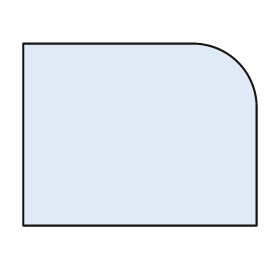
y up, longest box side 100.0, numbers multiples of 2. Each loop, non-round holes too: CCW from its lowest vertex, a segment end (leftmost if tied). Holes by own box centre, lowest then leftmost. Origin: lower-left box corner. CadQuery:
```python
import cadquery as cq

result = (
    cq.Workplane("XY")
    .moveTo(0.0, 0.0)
    .lineTo(100.0, 0.0)
    .lineTo(100.0, 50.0)
    .threePointArc((92.0, 70.0), (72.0, 78.0))
    .lineTo(0.0, 78.0)
    .close()
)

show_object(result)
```